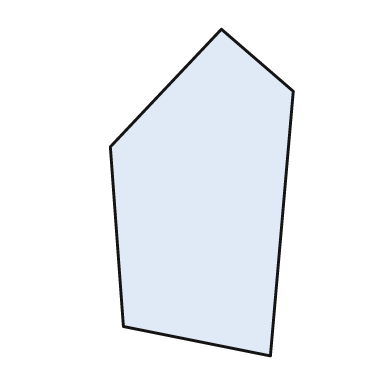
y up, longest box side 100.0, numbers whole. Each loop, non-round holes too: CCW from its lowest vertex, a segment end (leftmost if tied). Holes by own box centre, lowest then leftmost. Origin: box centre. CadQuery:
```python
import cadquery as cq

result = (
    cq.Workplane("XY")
    .moveTo(21.0, -50.0)
    .lineTo(28.0, 31.0)
    .lineTo(6.0, 50.0)
    .lineTo(-28.0, 14.0)
    .lineTo(-24.0, -41.0)
    .close()
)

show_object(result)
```